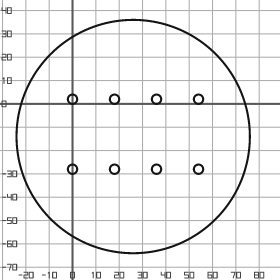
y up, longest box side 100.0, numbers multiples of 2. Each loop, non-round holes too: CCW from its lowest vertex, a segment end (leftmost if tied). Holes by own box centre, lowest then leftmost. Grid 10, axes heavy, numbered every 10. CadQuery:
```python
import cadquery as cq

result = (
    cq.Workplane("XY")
    .moveTo(26.0, -14.0)
    .circle(50.0)
    .moveTo(0.0, -28.0)
    .circle(2.0)
    .moveTo(18.0, -28.0)
    .circle(2.0)
    .moveTo(36.0, -28.0)
    .circle(2.0)
    .moveTo(54.0, -28.0)
    .circle(2.0)
    .moveTo(0.0, 2.0)
    .circle(2.0)
    .moveTo(18.0, 2.0)
    .circle(2.0)
    .moveTo(36.0, 2.0)
    .circle(2.0)
    .moveTo(54.0, 2.0)
    .circle(2.0)
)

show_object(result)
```